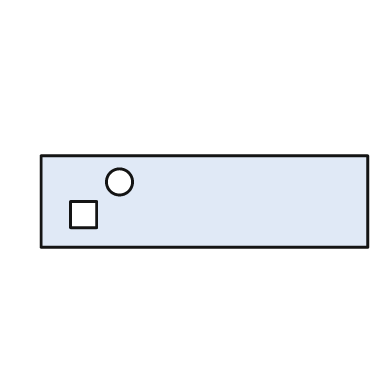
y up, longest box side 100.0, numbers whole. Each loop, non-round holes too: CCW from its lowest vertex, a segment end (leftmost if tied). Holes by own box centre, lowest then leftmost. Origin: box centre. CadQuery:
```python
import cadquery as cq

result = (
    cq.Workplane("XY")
    .moveTo(-50.0, -14.0)
    .lineTo(50.0, -14.0)
    .lineTo(50.0, 14.0)
    .lineTo(-50.0, 14.0)
    .close()
    .moveTo(-41.0, -8.0)
    .lineTo(-33.0, -8.0)
    .lineTo(-33.0, 0.0)
    .lineTo(-41.0, 0.0)
    .close()
    .moveTo(-26.0, 6.0)
    .circle(4.0)
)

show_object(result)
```